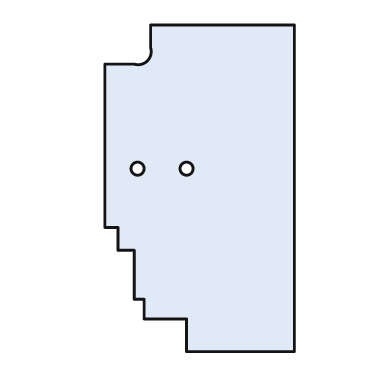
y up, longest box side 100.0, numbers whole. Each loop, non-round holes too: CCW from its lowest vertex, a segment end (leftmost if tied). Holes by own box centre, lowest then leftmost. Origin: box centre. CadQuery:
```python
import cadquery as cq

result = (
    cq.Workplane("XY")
    .moveTo(-4.0, -50.0)
    .lineTo(29.0, -50.0)
    .lineTo(29.0, 50.0)
    .lineTo(-15.0, 50.0)
    .lineTo(-15.0, 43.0)
    .threePointArc((-16.0, 39.0), (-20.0, 38.0))
    .lineTo(-29.0, 38.0)
    .lineTo(-29.0, -12.0)
    .lineTo(-25.0, -12.0)
    .lineTo(-25.0, -19.0)
    .lineTo(-20.0, -19.0)
    .lineTo(-20.0, -34.0)
    .lineTo(-17.0, -34.0)
    .lineTo(-17.0, -40.0)
    .lineTo(-4.0, -40.0)
    .close()
    .moveTo(-19.0, 6.0)
    .circle(2.0)
    .moveTo(-4.0, 6.0)
    .circle(2.0)
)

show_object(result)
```